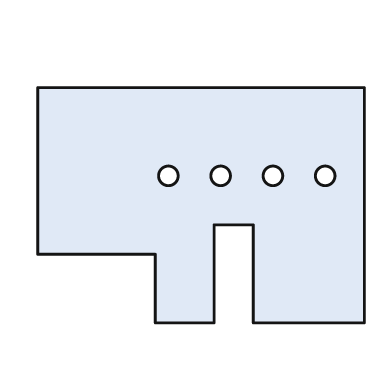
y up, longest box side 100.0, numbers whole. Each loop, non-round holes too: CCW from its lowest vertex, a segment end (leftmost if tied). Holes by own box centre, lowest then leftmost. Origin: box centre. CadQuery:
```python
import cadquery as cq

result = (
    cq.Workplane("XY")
    .moveTo(-14.0, -36.0)
    .lineTo(4.0, -36.0)
    .lineTo(4.0, -6.0)
    .lineTo(16.0, -6.0)
    .lineTo(16.0, -36.0)
    .lineTo(50.0, -36.0)
    .lineTo(50.0, 36.0)
    .lineTo(-50.0, 36.0)
    .lineTo(-50.0, -15.0)
    .lineTo(-14.0, -15.0)
    .close()
    .moveTo(-10.0, 9.0)
    .circle(3.0)
    .moveTo(6.0, 9.0)
    .circle(3.0)
    .moveTo(22.0, 9.0)
    .circle(3.0)
    .moveTo(38.0, 9.0)
    .circle(3.0)
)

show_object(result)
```